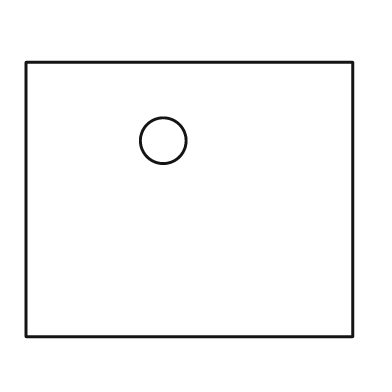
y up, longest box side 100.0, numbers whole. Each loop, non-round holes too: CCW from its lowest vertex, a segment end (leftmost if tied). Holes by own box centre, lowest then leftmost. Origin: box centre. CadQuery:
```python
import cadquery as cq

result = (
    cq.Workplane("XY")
    .moveTo(-50.0, -42.0)
    .lineTo(50.0, -42.0)
    .lineTo(50.0, 42.0)
    .lineTo(-50.0, 42.0)
    .close()
    .moveTo(-8.0, 18.0)
    .circle(7.0)
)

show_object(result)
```